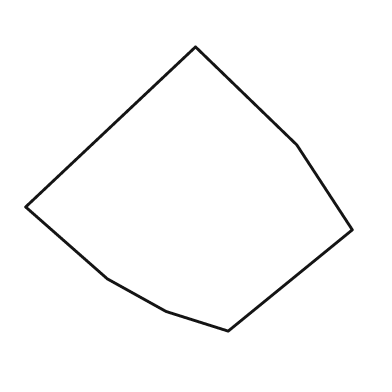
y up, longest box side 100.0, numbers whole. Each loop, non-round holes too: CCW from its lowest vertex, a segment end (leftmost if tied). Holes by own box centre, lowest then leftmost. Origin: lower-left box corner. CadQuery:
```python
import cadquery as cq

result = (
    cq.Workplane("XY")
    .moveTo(62.0, 0.0)
    .lineTo(100.0, 31.0)
    .lineTo(83.0, 57.0)
    .lineTo(52.0, 87.0)
    .lineTo(0.0, 38.0)
    .lineTo(25.0, 16.0)
    .lineTo(43.0, 6.0)
    .close()
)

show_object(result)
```